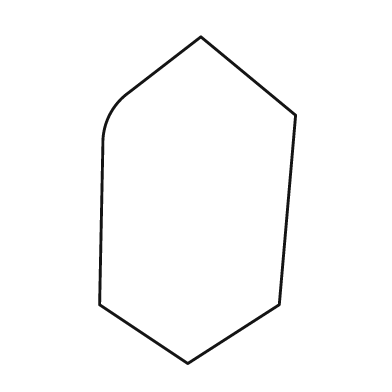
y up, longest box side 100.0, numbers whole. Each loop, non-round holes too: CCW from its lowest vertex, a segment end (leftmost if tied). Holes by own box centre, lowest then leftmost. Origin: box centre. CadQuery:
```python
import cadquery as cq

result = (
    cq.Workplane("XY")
    .moveTo(-3.0, -50.0)
    .lineTo(25.0, -32.0)
    .lineTo(30.0, 26.0)
    .lineTo(1.0, 50.0)
    .lineTo(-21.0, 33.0)
    .threePointArc((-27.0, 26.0), (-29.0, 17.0))
    .lineTo(-30.0, -32.0)
    .close()
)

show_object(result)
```